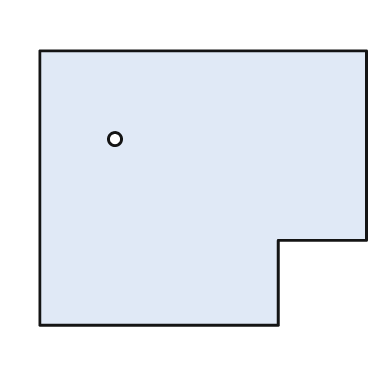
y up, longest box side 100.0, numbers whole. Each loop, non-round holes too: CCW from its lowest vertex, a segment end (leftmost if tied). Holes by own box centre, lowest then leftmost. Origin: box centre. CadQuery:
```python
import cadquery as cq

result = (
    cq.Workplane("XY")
    .moveTo(-50.0, -42.0)
    .lineTo(23.0, -42.0)
    .lineTo(23.0, -16.0)
    .lineTo(50.0, -16.0)
    .lineTo(50.0, 42.0)
    .lineTo(-50.0, 42.0)
    .close()
    .moveTo(-27.0, 15.0)
    .circle(2.0)
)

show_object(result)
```